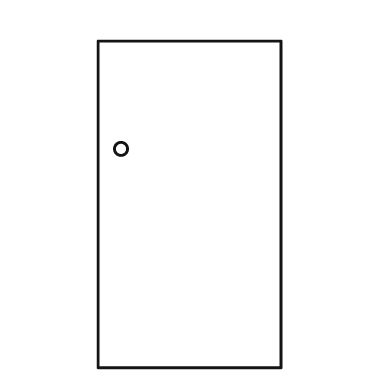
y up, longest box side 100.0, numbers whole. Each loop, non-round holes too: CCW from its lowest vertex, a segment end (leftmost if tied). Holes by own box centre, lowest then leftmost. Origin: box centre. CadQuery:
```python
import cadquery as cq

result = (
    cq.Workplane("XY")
    .moveTo(-28.0, -50.0)
    .lineTo(28.0, -50.0)
    .lineTo(28.0, 50.0)
    .lineTo(-28.0, 50.0)
    .close()
    .moveTo(-21.0, 17.0)
    .circle(2.0)
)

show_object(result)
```